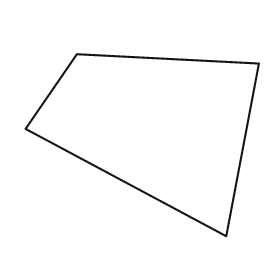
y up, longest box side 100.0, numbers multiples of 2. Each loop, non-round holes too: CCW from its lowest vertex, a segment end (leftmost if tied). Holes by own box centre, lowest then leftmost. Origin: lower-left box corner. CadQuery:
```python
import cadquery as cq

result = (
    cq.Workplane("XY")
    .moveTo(86.0, 0.0)
    .lineTo(100.0, 74.0)
    .lineTo(22.0, 78.0)
    .lineTo(0.0, 46.0)
    .close()
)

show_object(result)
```